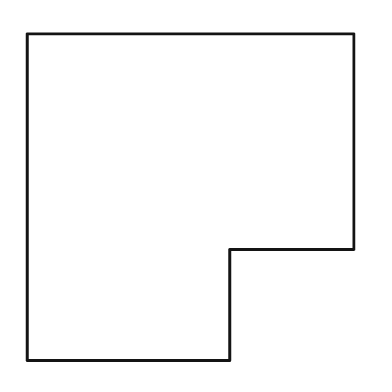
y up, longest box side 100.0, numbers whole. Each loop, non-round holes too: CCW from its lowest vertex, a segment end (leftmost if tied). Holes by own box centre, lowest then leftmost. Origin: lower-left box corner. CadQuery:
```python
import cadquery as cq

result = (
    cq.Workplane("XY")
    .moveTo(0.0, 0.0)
    .lineTo(62.0, 0.0)
    .lineTo(62.0, 34.0)
    .lineTo(100.0, 34.0)
    .lineTo(100.0, 100.0)
    .lineTo(0.0, 100.0)
    .close()
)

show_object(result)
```